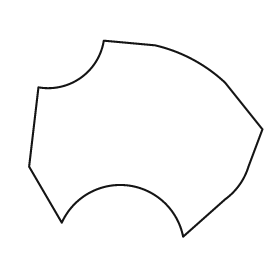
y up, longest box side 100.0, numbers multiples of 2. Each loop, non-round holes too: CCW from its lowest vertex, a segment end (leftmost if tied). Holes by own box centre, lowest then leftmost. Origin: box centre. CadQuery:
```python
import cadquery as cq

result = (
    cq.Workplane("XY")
    .moveTo(16.0, -42.0)
    .lineTo(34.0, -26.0)
    .threePointArc((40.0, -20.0), (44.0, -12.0))
    .lineTo(50.0, 4.0)
    .lineTo(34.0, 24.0)
    .threePointArc((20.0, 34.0), (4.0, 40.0))
    .lineTo(-18.0, 42.0)
    .threePointArc((-28.0, 26.0), (-46.0, 22.0))
    .lineTo(-50.0, -12.0)
    .lineTo(-36.0, -36.0)
    .threePointArc((-8.0, -20.0), (16.0, -42.0))
    .close()
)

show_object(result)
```